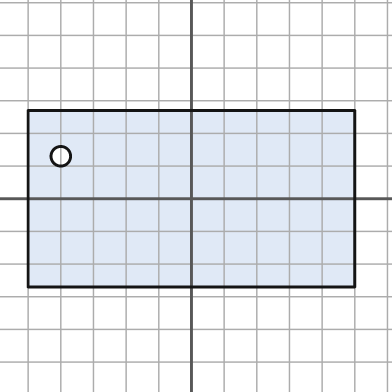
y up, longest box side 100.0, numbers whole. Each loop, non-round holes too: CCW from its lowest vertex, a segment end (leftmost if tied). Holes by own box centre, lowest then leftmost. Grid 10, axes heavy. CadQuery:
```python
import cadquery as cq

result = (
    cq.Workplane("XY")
    .moveTo(-50.0, -27.0)
    .lineTo(50.0, -27.0)
    .lineTo(50.0, 27.0)
    .lineTo(-50.0, 27.0)
    .close()
    .moveTo(-40.0, 13.0)
    .circle(3.0)
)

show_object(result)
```